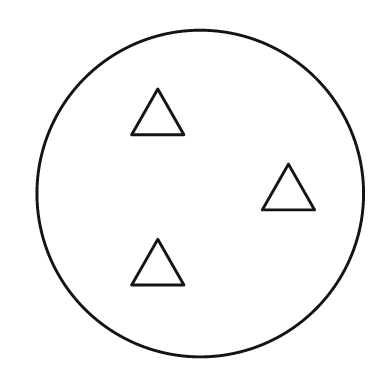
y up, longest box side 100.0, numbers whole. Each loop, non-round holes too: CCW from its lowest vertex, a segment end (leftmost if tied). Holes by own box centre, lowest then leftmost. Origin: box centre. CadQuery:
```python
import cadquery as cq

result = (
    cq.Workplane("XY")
    .moveTo(0.0, 0.0)
    .circle(50.0)
    .moveTo(-21.0, -28.0)
    .lineTo(-5.0, -28.0)
    .lineTo(-13.0, -14.0)
    .close()
    .moveTo(19.0, -5.0)
    .lineTo(35.0, -5.0)
    .lineTo(27.0, 9.0)
    .close()
    .moveTo(-21.0, 18.0)
    .lineTo(-5.0, 18.0)
    .lineTo(-13.0, 32.0)
    .close()
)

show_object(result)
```